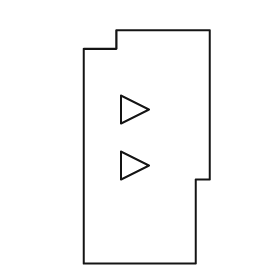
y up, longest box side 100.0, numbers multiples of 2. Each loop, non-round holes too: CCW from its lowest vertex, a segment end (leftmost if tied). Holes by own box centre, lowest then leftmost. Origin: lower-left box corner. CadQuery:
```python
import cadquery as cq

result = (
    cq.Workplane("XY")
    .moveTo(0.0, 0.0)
    .lineTo(48.0, 0.0)
    .lineTo(48.0, 36.0)
    .lineTo(54.0, 36.0)
    .lineTo(54.0, 100.0)
    .lineTo(14.0, 100.0)
    .lineTo(14.0, 92.0)
    .lineTo(0.0, 92.0)
    .close()
    .moveTo(16.0, 36.0)
    .lineTo(28.0, 42.0)
    .lineTo(16.0, 48.0)
    .close()
    .moveTo(16.0, 60.0)
    .lineTo(28.0, 66.0)
    .lineTo(16.0, 72.0)
    .close()
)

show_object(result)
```